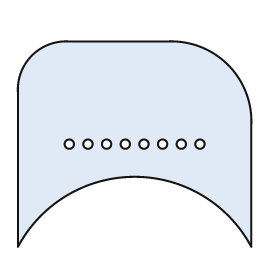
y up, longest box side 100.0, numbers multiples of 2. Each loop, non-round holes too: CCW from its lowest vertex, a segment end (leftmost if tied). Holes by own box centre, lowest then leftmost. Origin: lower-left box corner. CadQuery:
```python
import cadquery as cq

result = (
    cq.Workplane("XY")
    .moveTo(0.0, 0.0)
    .threePointArc((50.0, 30.0), (100.0, 0.0))
    .lineTo(100.0, 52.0)
    .threePointArc((90.0, 78.0), (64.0, 88.0))
    .lineTo(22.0, 88.0)
    .threePointArc((6.0, 82.0), (0.0, 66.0))
    .close()
    .moveTo(22.0, 44.0)
    .circle(2.0)
    .moveTo(30.0, 44.0)
    .circle(2.0)
    .moveTo(38.0, 44.0)
    .circle(2.0)
    .moveTo(46.0, 44.0)
    .circle(2.0)
    .moveTo(54.0, 44.0)
    .circle(2.0)
    .moveTo(62.0, 44.0)
    .circle(2.0)
    .moveTo(70.0, 44.0)
    .circle(2.0)
    .moveTo(78.0, 44.0)
    .circle(2.0)
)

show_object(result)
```